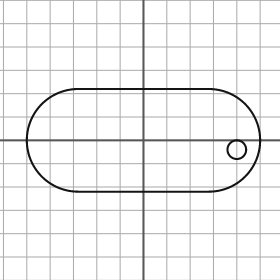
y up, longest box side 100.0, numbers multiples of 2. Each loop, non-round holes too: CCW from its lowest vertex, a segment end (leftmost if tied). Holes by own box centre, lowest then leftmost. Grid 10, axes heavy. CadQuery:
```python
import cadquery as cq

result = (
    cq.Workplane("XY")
    .moveTo(-28.0, -22.0)
    .lineTo(28.0, -22.0)
    .threePointArc((50.0, 0.0), (28.0, 22.0))
    .lineTo(-28.0, 22.0)
    .threePointArc((-50.0, 0.0), (-28.0, -22.0))
    .close()
    .moveTo(40.0, -4.0)
    .circle(4.0)
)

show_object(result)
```